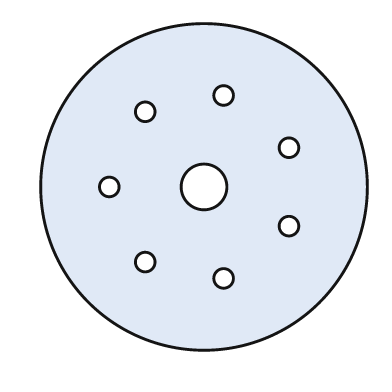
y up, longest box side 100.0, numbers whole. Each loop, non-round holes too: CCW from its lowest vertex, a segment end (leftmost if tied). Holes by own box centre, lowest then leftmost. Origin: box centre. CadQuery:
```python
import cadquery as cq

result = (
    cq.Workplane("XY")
    .moveTo(0.0, 0.0)
    .circle(50.0)
    .moveTo(6.0, -28.0)
    .circle(3.0)
    .moveTo(-18.0, -23.0)
    .circle(3.0)
    .moveTo(26.0, -12.0)
    .circle(3.0)
    .moveTo(-29.0, 0.0)
    .circle(3.0)
    .moveTo(0.0, 0.0)
    .circle(7.0)
    .moveTo(26.0, 12.0)
    .circle(3.0)
    .moveTo(-18.0, 23.0)
    .circle(3.0)
    .moveTo(6.0, 28.0)
    .circle(3.0)
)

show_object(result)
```